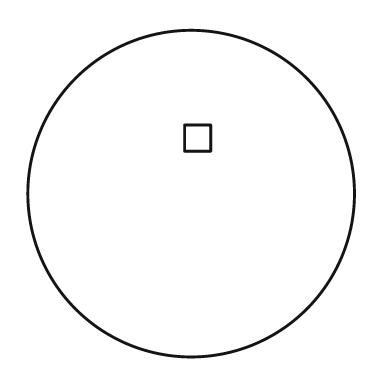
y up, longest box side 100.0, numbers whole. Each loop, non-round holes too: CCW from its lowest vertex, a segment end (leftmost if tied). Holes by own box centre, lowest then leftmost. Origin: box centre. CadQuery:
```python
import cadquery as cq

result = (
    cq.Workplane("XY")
    .moveTo(0.0, 0.0)
    .circle(50.0)
    .moveTo(-2.0, 13.0)
    .lineTo(6.0, 13.0)
    .lineTo(6.0, 21.0)
    .lineTo(-2.0, 21.0)
    .close()
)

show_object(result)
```